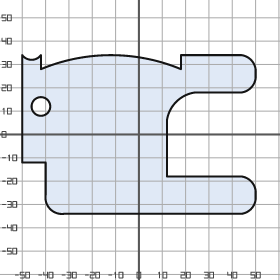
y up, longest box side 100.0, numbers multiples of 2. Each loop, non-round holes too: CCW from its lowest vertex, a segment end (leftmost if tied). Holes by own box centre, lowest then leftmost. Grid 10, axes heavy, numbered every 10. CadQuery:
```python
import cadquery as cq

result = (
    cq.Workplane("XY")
    .moveTo(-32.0, -34.0)
    .lineTo(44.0, -34.0)
    .threePointArc((48.0, -32.0), (50.0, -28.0))
    .lineTo(50.0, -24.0)
    .threePointArc((48.0, -20.0), (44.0, -18.0))
    .lineTo(12.0, -18.0)
    .lineTo(12.0, 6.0)
    .threePointArc((16.0, 14.0), (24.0, 18.0))
    .lineTo(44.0, 18.0)
    .threePointArc((48.0, 20.0), (50.0, 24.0))
    .lineTo(50.0, 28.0)
    .threePointArc((48.0, 32.0), (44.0, 34.0))
    .lineTo(18.0, 34.0)
    .lineTo(18.0, 28.0)
    .threePointArc((-12.0, 34.0), (-42.0, 28.0))
    .lineTo(-42.0, 34.0)
    .threePointArc((-46.0, 32.0), (-50.0, 34.0))
    .lineTo(-50.0, -12.0)
    .lineTo(-40.0, -12.0)
    .lineTo(-40.0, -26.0)
    .threePointArc((-38.0, -32.0), (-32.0, -34.0))
    .close()
    .moveTo(-42.0, 12.0)
    .circle(4.0)
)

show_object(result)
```